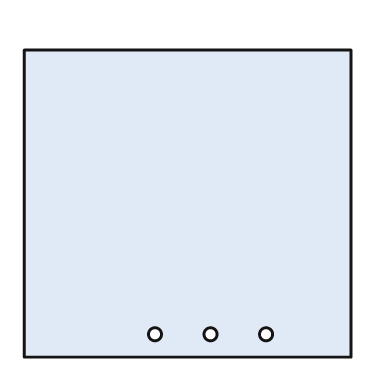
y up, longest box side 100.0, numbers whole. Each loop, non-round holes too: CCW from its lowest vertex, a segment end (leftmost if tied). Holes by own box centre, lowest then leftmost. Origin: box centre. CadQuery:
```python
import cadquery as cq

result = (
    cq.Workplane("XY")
    .moveTo(-50.0, -47.0)
    .lineTo(50.0, -47.0)
    .lineTo(50.0, 47.0)
    .lineTo(-50.0, 47.0)
    .close()
    .moveTo(-10.0, -40.0)
    .circle(2.0)
    .moveTo(7.0, -40.0)
    .circle(2.0)
    .moveTo(24.0, -40.0)
    .circle(2.0)
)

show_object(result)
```